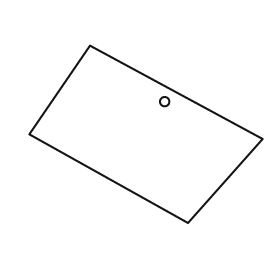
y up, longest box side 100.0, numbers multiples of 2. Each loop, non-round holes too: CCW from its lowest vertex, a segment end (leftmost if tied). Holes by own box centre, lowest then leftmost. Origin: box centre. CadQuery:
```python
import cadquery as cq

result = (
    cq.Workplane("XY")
    .moveTo(18.0, -38.0)
    .lineTo(50.0, -2.0)
    .lineTo(-24.0, 38.0)
    .lineTo(-50.0, 0.0)
    .close()
    .moveTo(8.0, 14.0)
    .circle(2.0)
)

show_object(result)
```